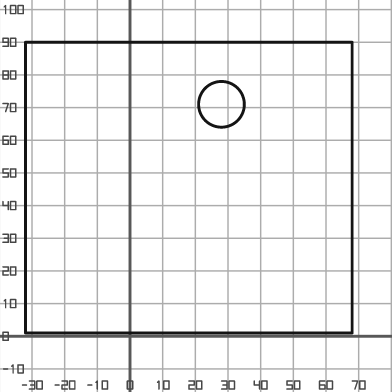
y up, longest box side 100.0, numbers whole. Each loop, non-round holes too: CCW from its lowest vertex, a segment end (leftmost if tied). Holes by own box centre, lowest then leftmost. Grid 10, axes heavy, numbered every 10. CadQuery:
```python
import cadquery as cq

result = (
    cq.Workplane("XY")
    .moveTo(-32.0, 1.0)
    .lineTo(68.0, 1.0)
    .lineTo(68.0, 90.0)
    .lineTo(-32.0, 90.0)
    .close()
    .moveTo(28.0, 71.0)
    .circle(7.0)
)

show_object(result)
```